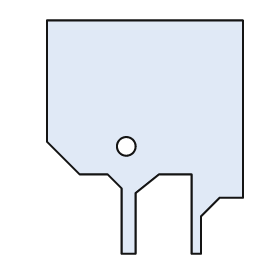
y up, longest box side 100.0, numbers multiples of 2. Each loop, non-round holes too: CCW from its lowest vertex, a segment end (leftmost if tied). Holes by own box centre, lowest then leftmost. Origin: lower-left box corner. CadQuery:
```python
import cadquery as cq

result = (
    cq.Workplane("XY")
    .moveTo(32.0, 0.0)
    .lineTo(38.0, 0.0)
    .lineTo(38.0, 26.0)
    .lineTo(48.0, 34.0)
    .lineTo(62.0, 34.0)
    .lineTo(62.0, 0.0)
    .lineTo(66.0, 0.0)
    .lineTo(66.0, 16.0)
    .lineTo(74.0, 24.0)
    .lineTo(84.0, 24.0)
    .lineTo(84.0, 100.0)
    .lineTo(0.0, 100.0)
    .lineTo(0.0, 48.0)
    .lineTo(14.0, 34.0)
    .lineTo(26.0, 34.0)
    .lineTo(32.0, 28.0)
    .close()
    .moveTo(34.0, 46.0)
    .circle(4.0)
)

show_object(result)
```